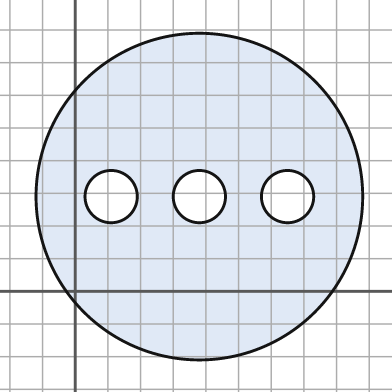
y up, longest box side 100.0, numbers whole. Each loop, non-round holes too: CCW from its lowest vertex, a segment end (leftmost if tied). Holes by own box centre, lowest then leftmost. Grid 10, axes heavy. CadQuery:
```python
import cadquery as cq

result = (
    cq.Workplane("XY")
    .moveTo(38.0, 29.0)
    .circle(50.0)
    .moveTo(11.0, 29.0)
    .circle(8.0)
    .moveTo(38.0, 29.0)
    .circle(8.0)
    .moveTo(65.0, 29.0)
    .circle(8.0)
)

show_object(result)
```